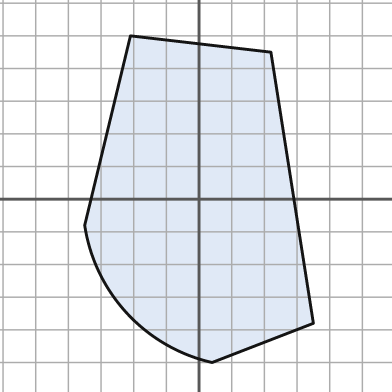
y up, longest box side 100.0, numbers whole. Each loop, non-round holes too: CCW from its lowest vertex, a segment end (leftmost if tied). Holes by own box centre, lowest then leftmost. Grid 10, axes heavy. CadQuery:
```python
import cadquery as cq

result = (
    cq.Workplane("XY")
    .moveTo(4.0, -50.0)
    .lineTo(35.0, -38.0)
    .lineTo(22.0, 45.0)
    .lineTo(-21.0, 50.0)
    .lineTo(-35.0, -8.0)
    .threePointArc((-22.0, -35.0), (4.0, -50.0))
    .close()
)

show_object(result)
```